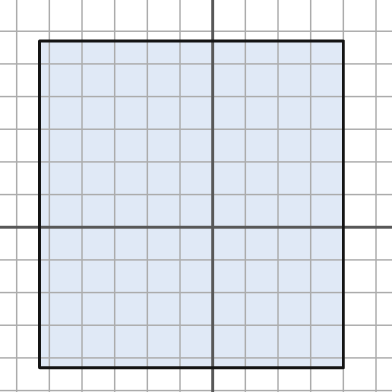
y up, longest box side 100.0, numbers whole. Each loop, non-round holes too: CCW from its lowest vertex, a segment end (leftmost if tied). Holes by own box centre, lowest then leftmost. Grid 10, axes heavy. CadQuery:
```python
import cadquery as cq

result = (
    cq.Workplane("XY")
    .moveTo(-53.0, -43.0)
    .lineTo(40.0, -43.0)
    .lineTo(40.0, 57.0)
    .lineTo(-53.0, 57.0)
    .close()
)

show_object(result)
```